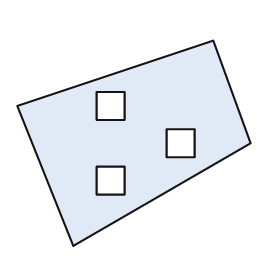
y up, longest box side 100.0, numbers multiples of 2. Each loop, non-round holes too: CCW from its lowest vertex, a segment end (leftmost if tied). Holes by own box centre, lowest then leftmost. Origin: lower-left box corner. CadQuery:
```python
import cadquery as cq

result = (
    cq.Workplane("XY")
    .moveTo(24.0, 0.0)
    .lineTo(100.0, 44.0)
    .lineTo(84.0, 88.0)
    .lineTo(0.0, 60.0)
    .close()
    .moveTo(34.0, 22.0)
    .lineTo(46.0, 22.0)
    .lineTo(46.0, 34.0)
    .lineTo(34.0, 34.0)
    .close()
    .moveTo(64.0, 38.0)
    .lineTo(76.0, 38.0)
    .lineTo(76.0, 50.0)
    .lineTo(64.0, 50.0)
    .close()
    .moveTo(34.0, 54.0)
    .lineTo(46.0, 54.0)
    .lineTo(46.0, 66.0)
    .lineTo(34.0, 66.0)
    .close()
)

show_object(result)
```